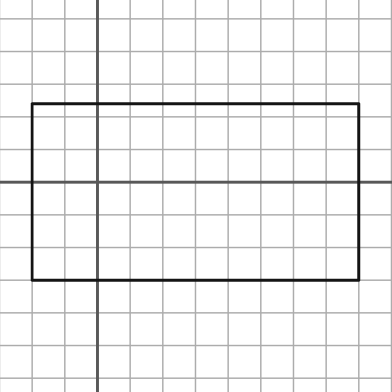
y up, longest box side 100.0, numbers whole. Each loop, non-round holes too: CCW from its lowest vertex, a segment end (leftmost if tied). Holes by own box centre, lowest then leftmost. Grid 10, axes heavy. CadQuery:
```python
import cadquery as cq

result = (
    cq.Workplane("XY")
    .moveTo(-20.0, -30.0)
    .lineTo(80.0, -30.0)
    .lineTo(80.0, 24.0)
    .lineTo(-20.0, 24.0)
    .close()
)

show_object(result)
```